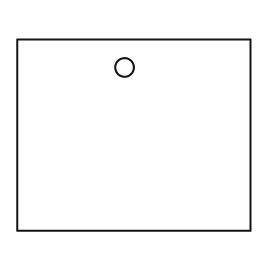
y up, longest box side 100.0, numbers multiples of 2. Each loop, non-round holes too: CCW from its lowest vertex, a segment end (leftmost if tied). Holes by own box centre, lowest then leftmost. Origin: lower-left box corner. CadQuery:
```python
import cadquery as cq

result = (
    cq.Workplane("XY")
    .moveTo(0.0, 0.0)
    .lineTo(100.0, 0.0)
    .lineTo(100.0, 82.0)
    .lineTo(0.0, 82.0)
    .close()
    .moveTo(46.0, 70.0)
    .circle(4.0)
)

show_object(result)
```